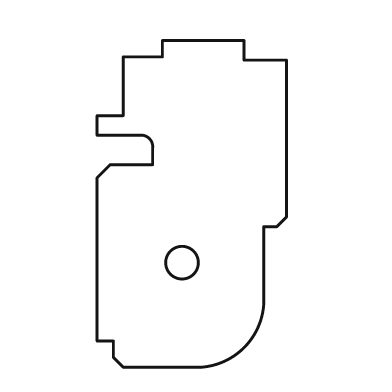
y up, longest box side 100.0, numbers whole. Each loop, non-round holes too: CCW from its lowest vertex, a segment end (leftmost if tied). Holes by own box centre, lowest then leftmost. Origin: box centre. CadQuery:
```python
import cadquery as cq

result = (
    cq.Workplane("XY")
    .moveTo(-21.0, -50.0)
    .lineTo(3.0, -50.0)
    .threePointArc((16.0, -44.0), (22.0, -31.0))
    .lineTo(22.0, -7.0)
    .lineTo(26.0, -7.0)
    .lineTo(29.0, -4.0)
    .lineTo(29.0, 44.0)
    .lineTo(16.0, 44.0)
    .lineTo(16.0, 50.0)
    .lineTo(-9.0, 50.0)
    .lineTo(-9.0, 45.0)
    .lineTo(-21.0, 45.0)
    .lineTo(-21.0, 27.0)
    .lineTo(-29.0, 27.0)
    .lineTo(-29.0, 21.0)
    .lineTo(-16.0, 21.0)
    .threePointArc((-13.0, 20.0), (-12.0, 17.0))
    .lineTo(-12.0, 12.0)
    .lineTo(-25.0, 12.0)
    .lineTo(-29.0, 8.0)
    .lineTo(-29.0, -42.0)
    .lineTo(-24.0, -42.0)
    .lineTo(-24.0, -47.0)
    .close()
    .moveTo(-3.0, -18.0)
    .circle(5.0)
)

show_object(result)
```